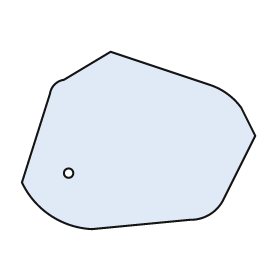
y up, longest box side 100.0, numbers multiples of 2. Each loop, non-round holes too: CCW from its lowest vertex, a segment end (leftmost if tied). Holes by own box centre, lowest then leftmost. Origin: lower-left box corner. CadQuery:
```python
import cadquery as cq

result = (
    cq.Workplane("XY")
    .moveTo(30.0, 0.0)
    .lineTo(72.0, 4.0)
    .threePointArc((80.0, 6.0), (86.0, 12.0))
    .lineTo(100.0, 40.0)
    .lineTo(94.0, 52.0)
    .threePointArc((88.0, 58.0), (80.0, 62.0))
    .lineTo(38.0, 76.0)
    .lineTo(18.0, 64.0)
    .threePointArc((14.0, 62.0), (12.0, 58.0))
    .lineTo(0.0, 20.0)
    .threePointArc((12.0, 6.0), (30.0, 0.0))
    .close()
    .moveTo(20.0, 24.0)
    .circle(2.0)
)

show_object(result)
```